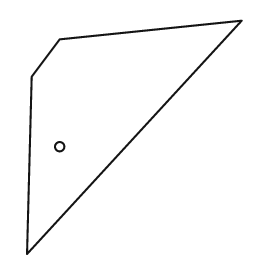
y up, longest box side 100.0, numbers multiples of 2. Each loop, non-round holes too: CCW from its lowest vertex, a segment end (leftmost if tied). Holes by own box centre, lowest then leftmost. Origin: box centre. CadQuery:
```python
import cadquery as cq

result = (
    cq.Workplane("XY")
    .moveTo(-46.0, -50.0)
    .lineTo(46.0, 50.0)
    .lineTo(-32.0, 42.0)
    .lineTo(-44.0, 26.0)
    .close()
    .moveTo(-32.0, -4.0)
    .circle(2.0)
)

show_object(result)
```